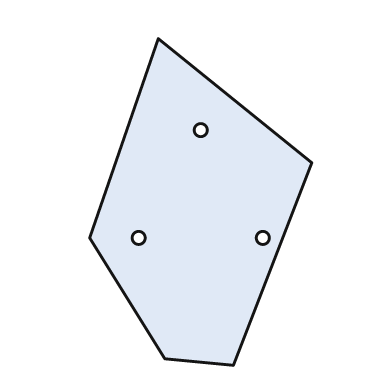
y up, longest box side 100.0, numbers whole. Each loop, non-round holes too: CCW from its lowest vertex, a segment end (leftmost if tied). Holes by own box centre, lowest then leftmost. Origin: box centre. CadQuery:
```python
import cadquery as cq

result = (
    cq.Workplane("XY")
    .moveTo(10.0, -50.0)
    .lineTo(34.0, 12.0)
    .lineTo(-13.0, 50.0)
    .lineTo(-34.0, -11.0)
    .lineTo(-11.0, -48.0)
    .close()
    .moveTo(-19.0, -11.0)
    .circle(2.0)
    .moveTo(19.0, -11.0)
    .circle(2.0)
    .moveTo(0.0, 22.0)
    .circle(2.0)
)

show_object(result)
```